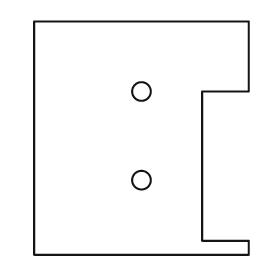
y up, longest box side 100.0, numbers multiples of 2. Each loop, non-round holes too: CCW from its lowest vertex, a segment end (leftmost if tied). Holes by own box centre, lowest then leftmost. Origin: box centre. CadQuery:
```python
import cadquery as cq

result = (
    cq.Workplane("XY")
    .moveTo(-46.0, -50.0)
    .lineTo(46.0, -50.0)
    .lineTo(46.0, -44.0)
    .lineTo(26.0, -44.0)
    .lineTo(26.0, 20.0)
    .lineTo(46.0, 20.0)
    .lineTo(46.0, 50.0)
    .lineTo(-46.0, 50.0)
    .close()
    .moveTo(0.0, -18.0)
    .circle(4.0)
    .moveTo(0.0, 20.0)
    .circle(4.0)
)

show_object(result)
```